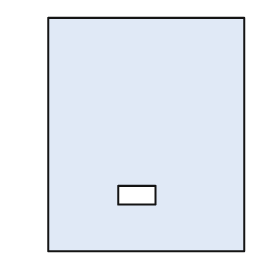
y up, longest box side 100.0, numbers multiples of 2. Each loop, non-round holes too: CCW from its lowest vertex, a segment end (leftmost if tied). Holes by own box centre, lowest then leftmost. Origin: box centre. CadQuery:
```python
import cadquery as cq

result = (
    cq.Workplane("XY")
    .moveTo(-42.0, -50.0)
    .lineTo(42.0, -50.0)
    .lineTo(42.0, 50.0)
    .lineTo(-42.0, 50.0)
    .close()
    .moveTo(-12.0, -30.0)
    .lineTo(4.0, -30.0)
    .lineTo(4.0, -22.0)
    .lineTo(-12.0, -22.0)
    .close()
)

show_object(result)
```